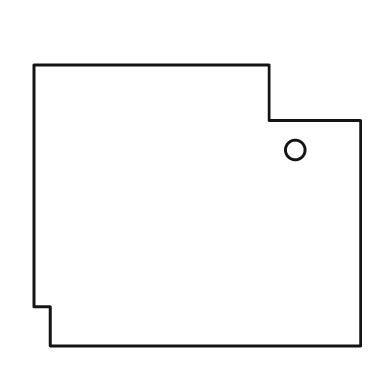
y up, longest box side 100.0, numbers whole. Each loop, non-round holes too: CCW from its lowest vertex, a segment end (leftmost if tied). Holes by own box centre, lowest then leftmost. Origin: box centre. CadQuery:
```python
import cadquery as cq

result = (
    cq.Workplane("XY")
    .moveTo(-45.0, -43.0)
    .lineTo(50.0, -43.0)
    .lineTo(50.0, 26.0)
    .lineTo(22.0, 26.0)
    .lineTo(22.0, 43.0)
    .lineTo(-50.0, 43.0)
    .lineTo(-50.0, -31.0)
    .lineTo(-45.0, -31.0)
    .close()
    .moveTo(30.0, 17.0)
    .circle(3.0)
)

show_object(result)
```